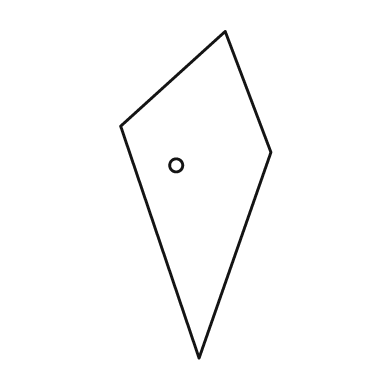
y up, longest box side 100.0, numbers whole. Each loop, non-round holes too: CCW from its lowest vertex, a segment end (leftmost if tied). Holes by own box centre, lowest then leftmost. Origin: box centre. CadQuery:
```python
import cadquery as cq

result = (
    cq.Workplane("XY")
    .moveTo(1.0, -50.0)
    .lineTo(23.0, 13.0)
    .lineTo(9.0, 50.0)
    .lineTo(-23.0, 21.0)
    .close()
    .moveTo(-6.0, 9.0)
    .circle(2.0)
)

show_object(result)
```